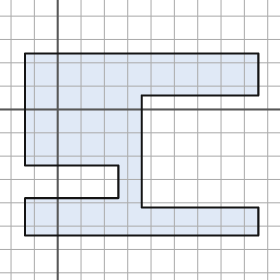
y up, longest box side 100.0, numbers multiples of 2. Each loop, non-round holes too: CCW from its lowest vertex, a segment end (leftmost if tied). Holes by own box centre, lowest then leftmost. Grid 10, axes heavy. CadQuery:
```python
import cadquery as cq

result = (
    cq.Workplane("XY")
    .moveTo(-14.0, -54.0)
    .lineTo(86.0, -54.0)
    .lineTo(86.0, -42.0)
    .lineTo(36.0, -42.0)
    .lineTo(36.0, 6.0)
    .lineTo(86.0, 6.0)
    .lineTo(86.0, 24.0)
    .lineTo(-14.0, 24.0)
    .lineTo(-14.0, -24.0)
    .lineTo(26.0, -24.0)
    .lineTo(26.0, -38.0)
    .lineTo(-14.0, -38.0)
    .close()
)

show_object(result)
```